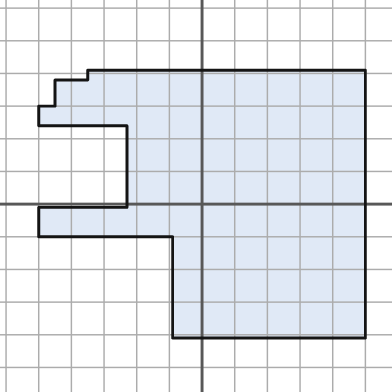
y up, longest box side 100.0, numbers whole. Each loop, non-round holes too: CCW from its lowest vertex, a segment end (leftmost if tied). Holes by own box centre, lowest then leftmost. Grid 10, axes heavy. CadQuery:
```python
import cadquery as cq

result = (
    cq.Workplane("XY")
    .moveTo(-9.0, -41.0)
    .lineTo(50.0, -41.0)
    .lineTo(50.0, 41.0)
    .lineTo(-35.0, 41.0)
    .lineTo(-35.0, 38.0)
    .lineTo(-45.0, 38.0)
    .lineTo(-45.0, 30.0)
    .lineTo(-50.0, 30.0)
    .lineTo(-50.0, 24.0)
    .lineTo(-23.0, 24.0)
    .lineTo(-23.0, -1.0)
    .lineTo(-50.0, -1.0)
    .lineTo(-50.0, -10.0)
    .lineTo(-9.0, -10.0)
    .close()
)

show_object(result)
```